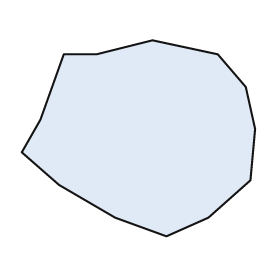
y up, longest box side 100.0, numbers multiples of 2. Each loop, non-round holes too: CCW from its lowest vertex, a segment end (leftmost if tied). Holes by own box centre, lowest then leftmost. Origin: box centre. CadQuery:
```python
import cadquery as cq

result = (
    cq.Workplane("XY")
    .moveTo(12.0, -42.0)
    .lineTo(30.0, -34.0)
    .lineTo(48.0, -18.0)
    .lineTo(50.0, 4.0)
    .lineTo(46.0, 22.0)
    .lineTo(34.0, 36.0)
    .lineTo(6.0, 42.0)
    .lineTo(-18.0, 36.0)
    .lineTo(-32.0, 36.0)
    .lineTo(-42.0, 8.0)
    .lineTo(-50.0, -6.0)
    .lineTo(-34.0, -20.0)
    .lineTo(-10.0, -34.0)
    .close()
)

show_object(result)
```